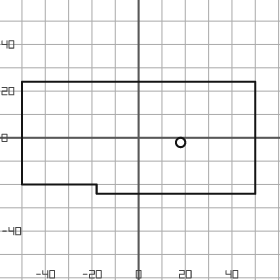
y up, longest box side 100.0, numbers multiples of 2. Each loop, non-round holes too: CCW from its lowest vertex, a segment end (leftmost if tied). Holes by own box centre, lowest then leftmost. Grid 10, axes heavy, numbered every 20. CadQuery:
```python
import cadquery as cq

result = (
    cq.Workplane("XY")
    .moveTo(-18.0, -24.0)
    .lineTo(50.0, -24.0)
    .lineTo(50.0, 24.0)
    .lineTo(-50.0, 24.0)
    .lineTo(-50.0, -20.0)
    .lineTo(-18.0, -20.0)
    .close()
    .moveTo(18.0, -2.0)
    .circle(2.0)
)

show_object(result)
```